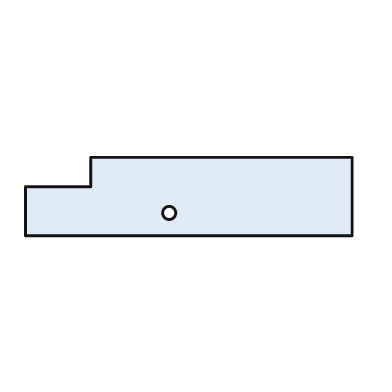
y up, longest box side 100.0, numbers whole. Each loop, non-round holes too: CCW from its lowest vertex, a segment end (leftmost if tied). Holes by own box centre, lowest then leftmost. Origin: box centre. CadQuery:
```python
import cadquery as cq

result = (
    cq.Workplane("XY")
    .moveTo(-50.0, -12.0)
    .lineTo(50.0, -12.0)
    .lineTo(50.0, 12.0)
    .lineTo(-30.0, 12.0)
    .lineTo(-30.0, 3.0)
    .lineTo(-50.0, 3.0)
    .close()
    .moveTo(-6.0, -5.0)
    .circle(2.0)
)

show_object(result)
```